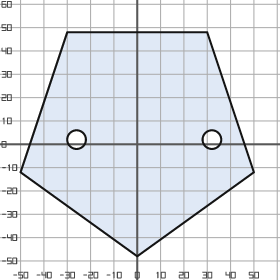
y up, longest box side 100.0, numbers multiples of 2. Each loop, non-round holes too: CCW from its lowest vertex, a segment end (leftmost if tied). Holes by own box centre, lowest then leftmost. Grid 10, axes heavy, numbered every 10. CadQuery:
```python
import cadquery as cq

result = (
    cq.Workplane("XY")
    .moveTo(0.0, -48.0)
    .lineTo(50.0, -12.0)
    .lineTo(30.0, 48.0)
    .lineTo(-30.0, 48.0)
    .lineTo(-50.0, -12.0)
    .close()
    .moveTo(-26.0, 2.0)
    .circle(4.0)
    .moveTo(32.0, 2.0)
    .circle(4.0)
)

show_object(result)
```